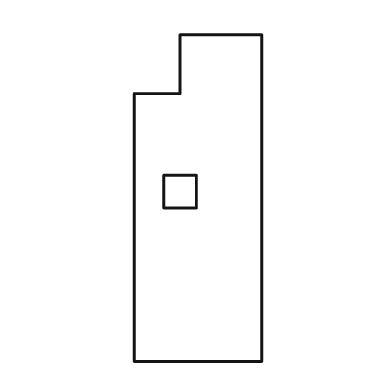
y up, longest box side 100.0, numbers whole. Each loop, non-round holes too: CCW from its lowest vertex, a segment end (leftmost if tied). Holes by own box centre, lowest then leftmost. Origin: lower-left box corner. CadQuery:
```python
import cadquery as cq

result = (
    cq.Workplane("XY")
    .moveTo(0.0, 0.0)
    .lineTo(39.0, 0.0)
    .lineTo(39.0, 100.0)
    .lineTo(14.0, 100.0)
    .lineTo(14.0, 82.0)
    .lineTo(0.0, 82.0)
    .close()
    .moveTo(9.0, 47.0)
    .lineTo(19.0, 47.0)
    .lineTo(19.0, 57.0)
    .lineTo(9.0, 57.0)
    .close()
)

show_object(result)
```